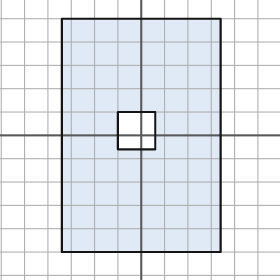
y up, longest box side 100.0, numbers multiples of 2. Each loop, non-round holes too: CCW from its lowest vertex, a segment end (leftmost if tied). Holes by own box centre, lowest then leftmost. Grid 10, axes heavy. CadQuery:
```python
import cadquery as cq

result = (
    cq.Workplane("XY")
    .moveTo(-34.0, -50.0)
    .lineTo(34.0, -50.0)
    .lineTo(34.0, 50.0)
    .lineTo(-34.0, 50.0)
    .close()
    .moveTo(-10.0, -6.0)
    .lineTo(6.0, -6.0)
    .lineTo(6.0, 10.0)
    .lineTo(-10.0, 10.0)
    .close()
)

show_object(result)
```